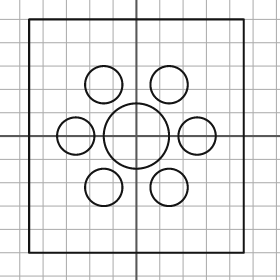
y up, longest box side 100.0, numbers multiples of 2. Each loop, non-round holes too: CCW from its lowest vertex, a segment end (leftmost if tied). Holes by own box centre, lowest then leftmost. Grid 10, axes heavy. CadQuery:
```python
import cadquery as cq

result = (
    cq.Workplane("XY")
    .moveTo(-46.0, -50.0)
    .lineTo(46.0, -50.0)
    .lineTo(46.0, 50.0)
    .lineTo(-46.0, 50.0)
    .close()
    .moveTo(-14.0, -22.0)
    .circle(8.0)
    .moveTo(14.0, -22.0)
    .circle(8.0)
    .moveTo(-26.0, 0.0)
    .circle(8.0)
    .moveTo(0.0, 0.0)
    .circle(14.0)
    .moveTo(26.0, 0.0)
    .circle(8.0)
    .moveTo(-14.0, 22.0)
    .circle(8.0)
    .moveTo(14.0, 22.0)
    .circle(8.0)
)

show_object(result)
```